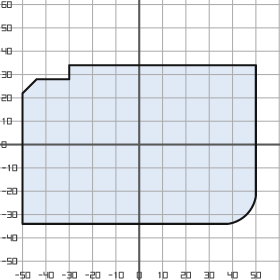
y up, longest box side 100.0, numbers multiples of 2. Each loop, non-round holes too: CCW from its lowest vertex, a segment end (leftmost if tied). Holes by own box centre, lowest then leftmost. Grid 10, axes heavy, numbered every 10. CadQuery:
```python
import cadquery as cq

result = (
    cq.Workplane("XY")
    .moveTo(-50.0, -34.0)
    .lineTo(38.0, -34.0)
    .threePointArc((46.0, -30.0), (50.0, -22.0))
    .lineTo(50.0, 34.0)
    .lineTo(-30.0, 34.0)
    .lineTo(-30.0, 28.0)
    .lineTo(-44.0, 28.0)
    .lineTo(-50.0, 22.0)
    .close()
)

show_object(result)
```